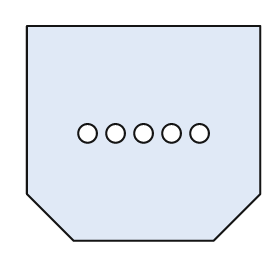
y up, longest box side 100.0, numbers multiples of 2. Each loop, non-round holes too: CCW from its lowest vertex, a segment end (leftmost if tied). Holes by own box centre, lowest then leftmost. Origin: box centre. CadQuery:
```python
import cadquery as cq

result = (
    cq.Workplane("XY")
    .moveTo(-30.0, -46.0)
    .lineTo(30.0, -46.0)
    .lineTo(50.0, -26.0)
    .lineTo(50.0, 46.0)
    .lineTo(-50.0, 46.0)
    .lineTo(-50.0, -26.0)
    .close()
    .moveTo(-24.0, 0.0)
    .circle(4.0)
    .moveTo(-12.0, 0.0)
    .circle(4.0)
    .moveTo(0.0, 0.0)
    .circle(4.0)
    .moveTo(12.0, 0.0)
    .circle(4.0)
    .moveTo(24.0, 0.0)
    .circle(4.0)
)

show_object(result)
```